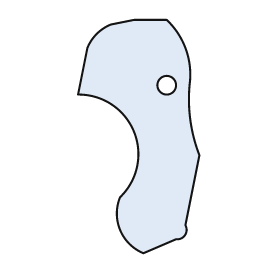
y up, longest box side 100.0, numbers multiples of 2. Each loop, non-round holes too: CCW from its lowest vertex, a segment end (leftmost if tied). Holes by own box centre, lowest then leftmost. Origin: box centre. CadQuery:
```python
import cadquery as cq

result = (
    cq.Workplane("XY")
    .moveTo(2.0, -50.0)
    .lineTo(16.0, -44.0)
    .threePointArc((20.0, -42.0), (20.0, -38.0))
    .lineTo(26.0, -8.0)
    .threePointArc((22.0, 8.0), (22.0, 24.0))
    .threePointArc((20.0, 38.0), (12.0, 50.0))
    .lineTo(-2.0, 50.0)
    .lineTo(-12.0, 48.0)
    .threePointArc((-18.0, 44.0), (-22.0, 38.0))
    .lineTo(-26.0, 18.0)
    .threePointArc((-2.0, 2.0), (-8.0, -26.0))
    .threePointArc((-8.0, -40.0), (2.0, -50.0))
    .close()
    .moveTo(12.0, 22.0)
    .circle(4.0)
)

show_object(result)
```